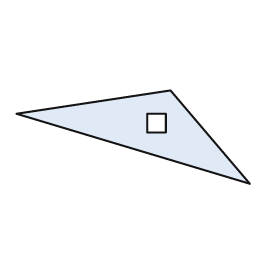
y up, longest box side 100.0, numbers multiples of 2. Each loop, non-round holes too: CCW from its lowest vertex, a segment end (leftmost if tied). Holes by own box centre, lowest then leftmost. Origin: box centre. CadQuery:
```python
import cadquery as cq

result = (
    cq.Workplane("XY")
    .moveTo(50.0, -20.0)
    .lineTo(16.0, 20.0)
    .lineTo(-50.0, 10.0)
    .close()
    .moveTo(6.0, 2.0)
    .lineTo(14.0, 2.0)
    .lineTo(14.0, 10.0)
    .lineTo(6.0, 10.0)
    .close()
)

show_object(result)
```